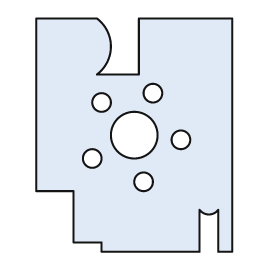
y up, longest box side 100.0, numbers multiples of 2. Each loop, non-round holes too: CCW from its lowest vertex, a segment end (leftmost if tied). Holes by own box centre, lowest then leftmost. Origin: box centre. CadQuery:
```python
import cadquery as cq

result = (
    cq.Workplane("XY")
    .moveTo(-14.0, -50.0)
    .lineTo(28.0, -50.0)
    .lineTo(28.0, -32.0)
    .threePointArc((32.0, -34.0), (36.0, -32.0))
    .lineTo(36.0, -50.0)
    .lineTo(42.0, -50.0)
    .lineTo(42.0, 50.0)
    .lineTo(2.0, 50.0)
    .lineTo(2.0, 26.0)
    .lineTo(-16.0, 26.0)
    .threePointArc((-10.0, 38.0), (-16.0, 50.0))
    .lineTo(-42.0, 50.0)
    .lineTo(-42.0, -24.0)
    .lineTo(-26.0, -24.0)
    .lineTo(-26.0, -46.0)
    .lineTo(-14.0, -46.0)
    .close()
    .moveTo(4.0, -20.0)
    .circle(4.0)
    .moveTo(-18.0, -10.0)
    .circle(4.0)
    .moveTo(20.0, -2.0)
    .circle(4.0)
    .moveTo(0.0, 0.0)
    .circle(10.0)
    .moveTo(-14.0, 14.0)
    .circle(4.0)
    .moveTo(8.0, 18.0)
    .circle(4.0)
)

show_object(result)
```